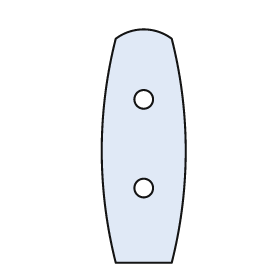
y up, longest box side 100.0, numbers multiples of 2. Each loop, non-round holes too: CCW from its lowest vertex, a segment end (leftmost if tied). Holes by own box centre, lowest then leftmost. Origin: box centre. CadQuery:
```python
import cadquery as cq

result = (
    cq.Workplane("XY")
    .moveTo(-12.0, -50.0)
    .lineTo(12.0, -50.0)
    .threePointArc((18.0, -2.0), (12.0, 46.0))
    .threePointArc((0.0, 50.0), (-12.0, 46.0))
    .threePointArc((-18.0, -2.0), (-12.0, -50.0))
    .close()
    .moveTo(0.0, -18.0)
    .circle(4.0)
    .moveTo(0.0, 20.0)
    .circle(4.0)
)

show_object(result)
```